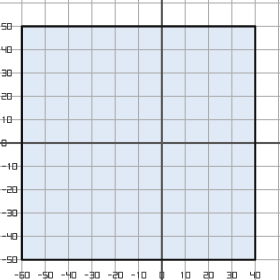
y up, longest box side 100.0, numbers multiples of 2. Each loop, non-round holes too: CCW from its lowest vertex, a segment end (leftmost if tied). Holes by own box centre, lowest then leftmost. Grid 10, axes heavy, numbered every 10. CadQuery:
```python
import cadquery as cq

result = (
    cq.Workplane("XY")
    .moveTo(-60.0, -50.0)
    .lineTo(40.0, -50.0)
    .lineTo(40.0, 50.0)
    .lineTo(-60.0, 50.0)
    .close()
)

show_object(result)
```